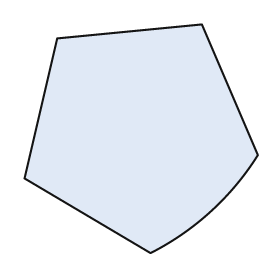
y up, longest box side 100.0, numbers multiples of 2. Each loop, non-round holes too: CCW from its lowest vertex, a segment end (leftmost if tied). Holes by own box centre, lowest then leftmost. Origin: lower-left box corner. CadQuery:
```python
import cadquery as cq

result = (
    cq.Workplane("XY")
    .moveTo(54.0, 0.0)
    .threePointArc((80.0, 18.0), (100.0, 42.0))
    .lineTo(76.0, 98.0)
    .lineTo(14.0, 92.0)
    .lineTo(0.0, 32.0)
    .close()
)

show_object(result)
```